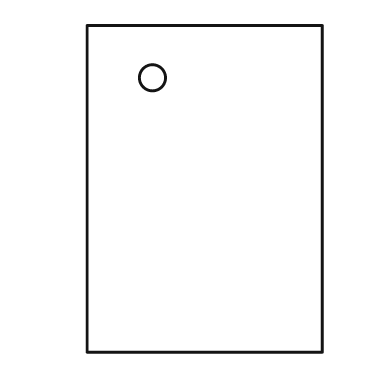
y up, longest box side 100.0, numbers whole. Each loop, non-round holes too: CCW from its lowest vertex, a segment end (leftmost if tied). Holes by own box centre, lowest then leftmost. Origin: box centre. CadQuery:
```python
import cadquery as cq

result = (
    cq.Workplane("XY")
    .moveTo(-36.0, -50.0)
    .lineTo(36.0, -50.0)
    .lineTo(36.0, 50.0)
    .lineTo(-36.0, 50.0)
    .close()
    .moveTo(-16.0, 34.0)
    .circle(4.0)
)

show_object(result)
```